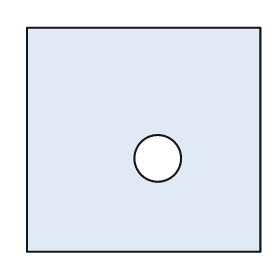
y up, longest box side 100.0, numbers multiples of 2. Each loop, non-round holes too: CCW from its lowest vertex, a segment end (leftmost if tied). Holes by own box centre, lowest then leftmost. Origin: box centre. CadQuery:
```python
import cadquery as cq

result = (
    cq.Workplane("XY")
    .moveTo(-50.0, -48.0)
    .lineTo(50.0, -48.0)
    .lineTo(50.0, 48.0)
    .lineTo(-50.0, 48.0)
    .close()
    .moveTo(6.0, -8.0)
    .circle(10.0)
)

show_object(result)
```